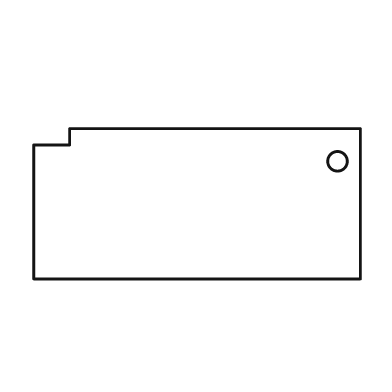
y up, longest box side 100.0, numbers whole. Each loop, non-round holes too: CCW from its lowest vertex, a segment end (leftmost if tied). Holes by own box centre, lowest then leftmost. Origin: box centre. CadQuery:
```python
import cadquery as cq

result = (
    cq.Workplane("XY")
    .moveTo(-50.0, -23.0)
    .lineTo(50.0, -23.0)
    .lineTo(50.0, 23.0)
    .lineTo(-39.0, 23.0)
    .lineTo(-39.0, 18.0)
    .lineTo(-50.0, 18.0)
    .close()
    .moveTo(43.0, 13.0)
    .circle(3.0)
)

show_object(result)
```